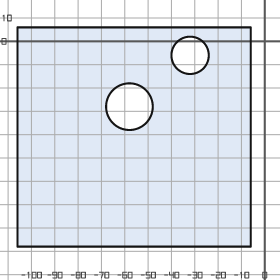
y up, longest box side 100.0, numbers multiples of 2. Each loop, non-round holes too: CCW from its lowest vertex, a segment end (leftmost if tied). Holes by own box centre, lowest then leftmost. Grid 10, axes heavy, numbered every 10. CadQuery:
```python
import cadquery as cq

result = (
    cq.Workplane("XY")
    .moveTo(-106.0, -88.0)
    .lineTo(-6.0, -88.0)
    .lineTo(-6.0, 6.0)
    .lineTo(-106.0, 6.0)
    .close()
    .moveTo(-58.0, -28.0)
    .circle(10.0)
    .moveTo(-32.0, -6.0)
    .circle(8.0)
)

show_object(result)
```